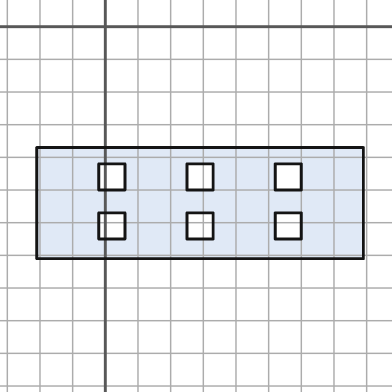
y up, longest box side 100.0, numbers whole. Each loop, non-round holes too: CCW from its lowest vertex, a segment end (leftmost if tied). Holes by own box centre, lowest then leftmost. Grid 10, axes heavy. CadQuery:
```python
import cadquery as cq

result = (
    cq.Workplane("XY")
    .moveTo(-21.0, -71.0)
    .lineTo(79.0, -71.0)
    .lineTo(79.0, -37.0)
    .lineTo(-21.0, -37.0)
    .close()
    .moveTo(-2.0, -65.0)
    .lineTo(6.0, -65.0)
    .lineTo(6.0, -57.0)
    .lineTo(-2.0, -57.0)
    .close()
    .moveTo(25.0, -65.0)
    .lineTo(33.0, -65.0)
    .lineTo(33.0, -57.0)
    .lineTo(25.0, -57.0)
    .close()
    .moveTo(52.0, -65.0)
    .lineTo(60.0, -65.0)
    .lineTo(60.0, -57.0)
    .lineTo(52.0, -57.0)
    .close()
    .moveTo(-2.0, -50.0)
    .lineTo(6.0, -50.0)
    .lineTo(6.0, -42.0)
    .lineTo(-2.0, -42.0)
    .close()
    .moveTo(25.0, -50.0)
    .lineTo(33.0, -50.0)
    .lineTo(33.0, -42.0)
    .lineTo(25.0, -42.0)
    .close()
    .moveTo(52.0, -50.0)
    .lineTo(60.0, -50.0)
    .lineTo(60.0, -42.0)
    .lineTo(52.0, -42.0)
    .close()
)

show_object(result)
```